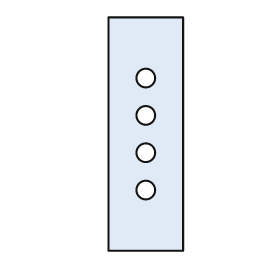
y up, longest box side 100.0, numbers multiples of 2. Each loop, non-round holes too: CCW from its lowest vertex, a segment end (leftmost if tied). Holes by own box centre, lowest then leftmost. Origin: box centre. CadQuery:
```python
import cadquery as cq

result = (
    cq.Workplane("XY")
    .moveTo(-16.0, -50.0)
    .lineTo(16.0, -50.0)
    .lineTo(16.0, 50.0)
    .lineTo(-16.0, 50.0)
    .close()
    .moveTo(0.0, -24.0)
    .circle(4.0)
    .moveTo(0.0, -8.0)
    .circle(4.0)
    .moveTo(0.0, 8.0)
    .circle(4.0)
    .moveTo(0.0, 24.0)
    .circle(4.0)
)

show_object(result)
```